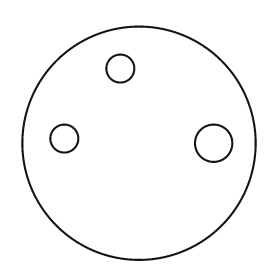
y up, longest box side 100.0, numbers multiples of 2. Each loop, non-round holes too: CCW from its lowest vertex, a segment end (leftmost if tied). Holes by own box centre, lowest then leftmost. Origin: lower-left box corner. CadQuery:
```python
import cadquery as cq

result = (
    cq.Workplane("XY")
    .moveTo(50.0, 50.0)
    .circle(50.0)
    .moveTo(82.0, 50.0)
    .circle(8.0)
    .moveTo(18.0, 52.0)
    .circle(6.0)
    .moveTo(42.0, 82.0)
    .circle(6.0)
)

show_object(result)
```